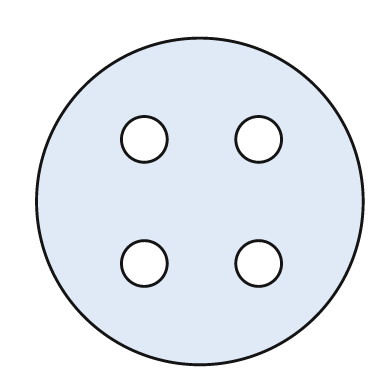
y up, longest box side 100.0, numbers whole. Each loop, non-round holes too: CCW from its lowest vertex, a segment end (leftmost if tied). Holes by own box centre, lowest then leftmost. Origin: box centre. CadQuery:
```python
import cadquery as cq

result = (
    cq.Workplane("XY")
    .moveTo(0.0, 0.0)
    .circle(50.0)
    .moveTo(-17.0, -19.0)
    .circle(7.0)
    .moveTo(18.0, -19.0)
    .circle(7.0)
    .moveTo(-17.0, 19.0)
    .circle(7.0)
    .moveTo(18.0, 19.0)
    .circle(7.0)
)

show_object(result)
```